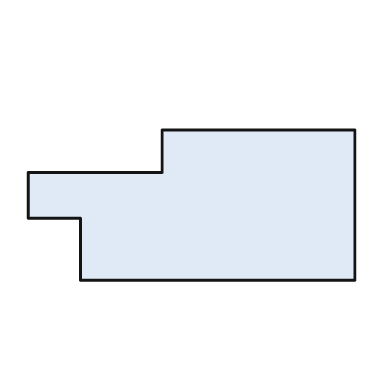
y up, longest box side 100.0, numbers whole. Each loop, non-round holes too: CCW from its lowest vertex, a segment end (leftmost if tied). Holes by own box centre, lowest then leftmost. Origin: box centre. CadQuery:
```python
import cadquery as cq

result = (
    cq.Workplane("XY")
    .moveTo(-34.0, -23.0)
    .lineTo(50.0, -23.0)
    .lineTo(50.0, 23.0)
    .lineTo(-9.0, 23.0)
    .lineTo(-9.0, 10.0)
    .lineTo(-50.0, 10.0)
    .lineTo(-50.0, -4.0)
    .lineTo(-34.0, -4.0)
    .close()
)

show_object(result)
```